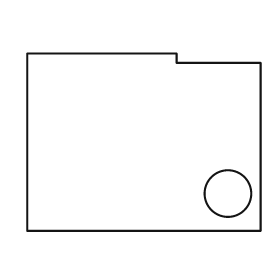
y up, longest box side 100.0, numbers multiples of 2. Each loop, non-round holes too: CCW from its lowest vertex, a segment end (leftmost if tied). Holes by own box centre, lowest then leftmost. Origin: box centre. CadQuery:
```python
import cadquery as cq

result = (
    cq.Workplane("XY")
    .moveTo(-50.0, -38.0)
    .lineTo(50.0, -38.0)
    .lineTo(50.0, 34.0)
    .lineTo(14.0, 34.0)
    .lineTo(14.0, 38.0)
    .lineTo(-50.0, 38.0)
    .close()
    .moveTo(36.0, -22.0)
    .circle(10.0)
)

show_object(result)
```